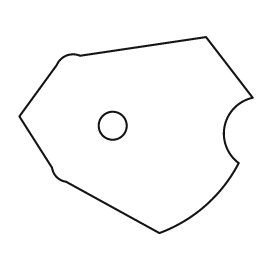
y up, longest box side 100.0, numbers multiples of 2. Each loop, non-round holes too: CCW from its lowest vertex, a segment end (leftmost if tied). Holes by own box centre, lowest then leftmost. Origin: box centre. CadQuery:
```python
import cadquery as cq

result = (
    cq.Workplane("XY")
    .moveTo(10.0, -42.0)
    .threePointArc((30.0, -30.0), (44.0, -12.0))
    .threePointArc((38.0, 4.0), (50.0, 16.0))
    .lineTo(30.0, 42.0)
    .lineTo(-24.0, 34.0)
    .threePointArc((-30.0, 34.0), (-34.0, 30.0))
    .lineTo(-50.0, 8.0)
    .lineTo(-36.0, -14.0)
    .threePointArc((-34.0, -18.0), (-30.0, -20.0))
    .close()
    .moveTo(-10.0, 4.0)
    .circle(6.0)
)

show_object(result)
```